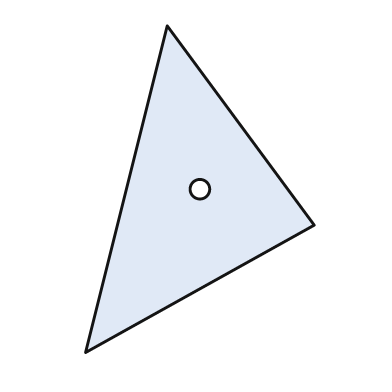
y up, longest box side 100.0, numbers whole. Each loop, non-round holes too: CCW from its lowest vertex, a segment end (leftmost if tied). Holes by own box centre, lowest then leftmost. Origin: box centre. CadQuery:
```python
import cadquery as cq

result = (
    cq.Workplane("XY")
    .moveTo(-35.0, -50.0)
    .lineTo(35.0, -11.0)
    .lineTo(-10.0, 50.0)
    .close()
    .moveTo(0.0, 0.0)
    .circle(3.0)
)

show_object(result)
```